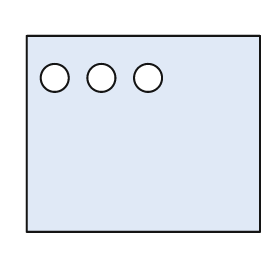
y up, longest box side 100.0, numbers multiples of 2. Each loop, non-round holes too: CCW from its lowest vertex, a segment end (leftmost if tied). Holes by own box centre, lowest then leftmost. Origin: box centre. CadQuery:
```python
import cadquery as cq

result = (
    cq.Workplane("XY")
    .moveTo(-50.0, -42.0)
    .lineTo(50.0, -42.0)
    .lineTo(50.0, 42.0)
    .lineTo(-50.0, 42.0)
    .close()
    .moveTo(-38.0, 24.0)
    .circle(6.0)
    .moveTo(-18.0, 24.0)
    .circle(6.0)
    .moveTo(2.0, 24.0)
    .circle(6.0)
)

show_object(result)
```